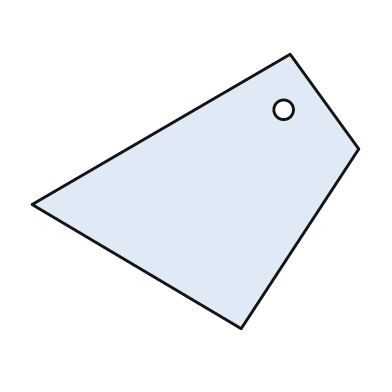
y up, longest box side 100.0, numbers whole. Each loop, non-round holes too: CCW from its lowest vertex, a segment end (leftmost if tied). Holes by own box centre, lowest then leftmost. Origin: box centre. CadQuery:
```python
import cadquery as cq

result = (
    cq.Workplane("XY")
    .moveTo(14.0, -42.0)
    .lineTo(50.0, 13.0)
    .lineTo(29.0, 42.0)
    .lineTo(-50.0, -4.0)
    .close()
    .moveTo(27.0, 25.0)
    .circle(3.0)
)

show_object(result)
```